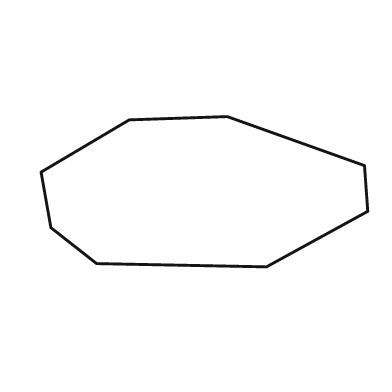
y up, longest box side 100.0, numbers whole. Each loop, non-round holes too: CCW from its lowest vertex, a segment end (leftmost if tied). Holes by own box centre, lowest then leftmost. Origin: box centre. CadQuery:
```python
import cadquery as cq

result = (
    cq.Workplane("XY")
    .moveTo(19.0, -23.0)
    .lineTo(50.0, -6.0)
    .lineTo(49.0, 8.0)
    .lineTo(7.0, 23.0)
    .lineTo(-23.0, 22.0)
    .lineTo(-50.0, 6.0)
    .lineTo(-47.0, -11.0)
    .lineTo(-33.0, -22.0)
    .close()
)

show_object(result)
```